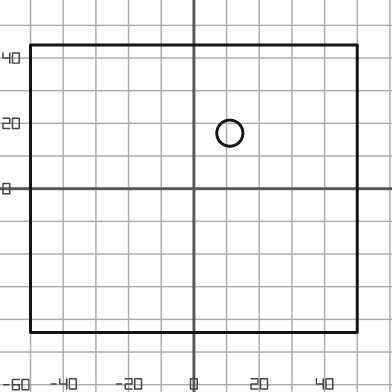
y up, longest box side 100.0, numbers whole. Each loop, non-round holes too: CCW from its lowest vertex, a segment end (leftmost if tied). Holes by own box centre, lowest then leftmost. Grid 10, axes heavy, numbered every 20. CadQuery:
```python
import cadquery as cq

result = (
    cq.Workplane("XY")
    .moveTo(-50.0, -44.0)
    .lineTo(50.0, -44.0)
    .lineTo(50.0, 44.0)
    .lineTo(-50.0, 44.0)
    .close()
    .moveTo(11.0, 17.0)
    .circle(4.0)
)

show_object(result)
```